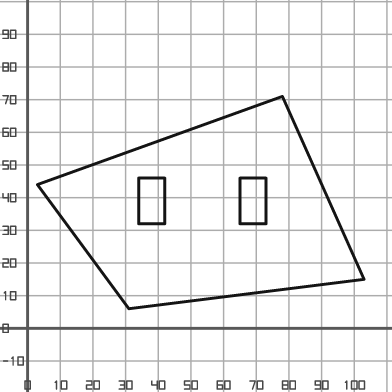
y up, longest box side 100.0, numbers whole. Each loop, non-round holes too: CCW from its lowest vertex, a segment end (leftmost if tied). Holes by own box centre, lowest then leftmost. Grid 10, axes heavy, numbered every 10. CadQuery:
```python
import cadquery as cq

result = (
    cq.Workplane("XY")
    .moveTo(31.0, 6.0)
    .lineTo(103.0, 15.0)
    .lineTo(78.0, 71.0)
    .lineTo(3.0, 44.0)
    .close()
    .moveTo(34.0, 32.0)
    .lineTo(42.0, 32.0)
    .lineTo(42.0, 46.0)
    .lineTo(34.0, 46.0)
    .close()
    .moveTo(65.0, 32.0)
    .lineTo(73.0, 32.0)
    .lineTo(73.0, 46.0)
    .lineTo(65.0, 46.0)
    .close()
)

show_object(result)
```